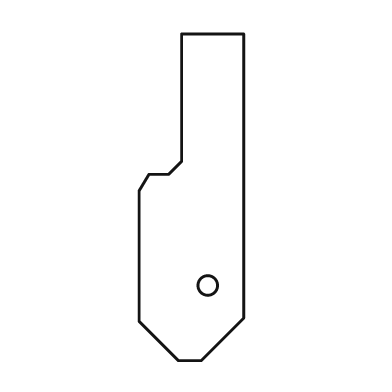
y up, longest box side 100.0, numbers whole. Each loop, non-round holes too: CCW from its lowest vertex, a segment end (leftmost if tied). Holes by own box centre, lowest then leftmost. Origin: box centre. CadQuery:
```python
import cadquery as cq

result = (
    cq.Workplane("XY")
    .moveTo(-4.0, -50.0)
    .lineTo(3.0, -50.0)
    .lineTo(16.0, -37.0)
    .lineTo(16.0, 50.0)
    .lineTo(-3.0, 50.0)
    .lineTo(-3.0, 11.0)
    .lineTo(-7.0, 7.0)
    .lineTo(-13.0, 7.0)
    .lineTo(-16.0, 2.0)
    .lineTo(-16.0, -38.0)
    .close()
    .moveTo(5.0, -27.0)
    .circle(3.0)
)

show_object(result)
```